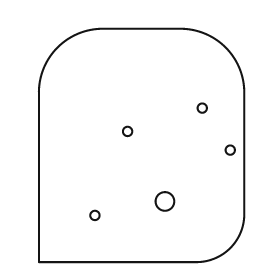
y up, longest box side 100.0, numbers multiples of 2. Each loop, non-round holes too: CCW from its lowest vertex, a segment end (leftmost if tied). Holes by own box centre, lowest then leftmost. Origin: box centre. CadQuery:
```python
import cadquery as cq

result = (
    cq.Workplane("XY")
    .moveTo(-44.0, -50.0)
    .lineTo(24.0, -50.0)
    .threePointArc((38.0, -44.0), (44.0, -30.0))
    .lineTo(44.0, 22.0)
    .threePointArc((36.0, 42.0), (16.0, 50.0))
    .lineTo(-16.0, 50.0)
    .threePointArc((-36.0, 42.0), (-44.0, 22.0))
    .close()
    .moveTo(-20.0, -30.0)
    .circle(2.0)
    .moveTo(10.0, -24.0)
    .circle(4.0)
    .moveTo(38.0, -2.0)
    .circle(2.0)
    .moveTo(-6.0, 6.0)
    .circle(2.0)
    .moveTo(26.0, 16.0)
    .circle(2.0)
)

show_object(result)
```